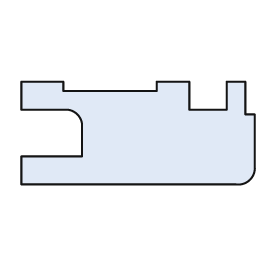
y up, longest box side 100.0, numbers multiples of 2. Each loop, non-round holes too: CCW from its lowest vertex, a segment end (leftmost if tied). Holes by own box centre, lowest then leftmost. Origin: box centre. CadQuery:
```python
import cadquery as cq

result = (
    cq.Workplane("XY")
    .moveTo(-50.0, -22.0)
    .lineTo(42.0, -22.0)
    .threePointArc((48.0, -20.0), (50.0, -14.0))
    .lineTo(50.0, 8.0)
    .lineTo(46.0, 8.0)
    .lineTo(46.0, 22.0)
    .lineTo(38.0, 22.0)
    .lineTo(38.0, 10.0)
    .lineTo(22.0, 10.0)
    .lineTo(22.0, 22.0)
    .lineTo(8.0, 22.0)
    .lineTo(8.0, 18.0)
    .lineTo(-32.0, 18.0)
    .lineTo(-32.0, 22.0)
    .lineTo(-50.0, 22.0)
    .lineTo(-50.0, 10.0)
    .lineTo(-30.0, 10.0)
    .threePointArc((-26.0, 8.0), (-24.0, 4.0))
    .lineTo(-24.0, -10.0)
    .lineTo(-50.0, -10.0)
    .close()
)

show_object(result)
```